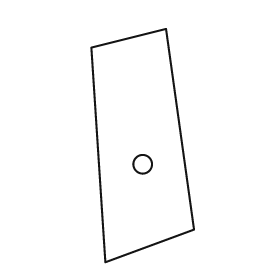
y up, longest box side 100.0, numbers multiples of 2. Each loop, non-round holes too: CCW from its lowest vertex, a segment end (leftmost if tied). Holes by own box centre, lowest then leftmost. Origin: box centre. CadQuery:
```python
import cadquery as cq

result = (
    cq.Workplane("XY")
    .moveTo(-16.0, -50.0)
    .lineTo(22.0, -36.0)
    .lineTo(10.0, 50.0)
    .lineTo(-22.0, 42.0)
    .close()
    .moveTo(0.0, -8.0)
    .circle(4.0)
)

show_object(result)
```